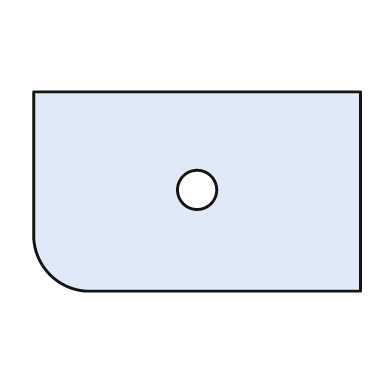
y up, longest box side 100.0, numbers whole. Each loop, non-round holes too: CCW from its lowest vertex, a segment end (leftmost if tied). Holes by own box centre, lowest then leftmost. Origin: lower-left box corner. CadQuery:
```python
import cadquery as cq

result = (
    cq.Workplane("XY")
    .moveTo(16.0, 0.0)
    .lineTo(100.0, 0.0)
    .lineTo(100.0, 61.0)
    .lineTo(0.0, 61.0)
    .lineTo(0.0, 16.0)
    .threePointArc((5.0, 5.0), (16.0, 0.0))
    .close()
    .moveTo(50.0, 31.0)
    .circle(6.0)
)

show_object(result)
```